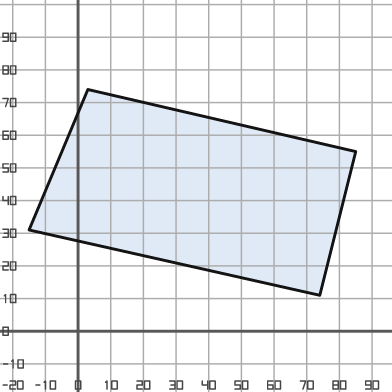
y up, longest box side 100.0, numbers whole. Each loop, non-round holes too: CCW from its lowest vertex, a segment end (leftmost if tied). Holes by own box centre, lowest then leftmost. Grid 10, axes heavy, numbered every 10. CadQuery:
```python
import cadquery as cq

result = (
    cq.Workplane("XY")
    .moveTo(74.0, 11.0)
    .lineTo(85.0, 55.0)
    .lineTo(3.0, 74.0)
    .lineTo(-15.0, 31.0)
    .close()
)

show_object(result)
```